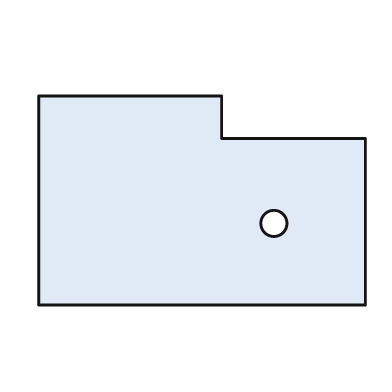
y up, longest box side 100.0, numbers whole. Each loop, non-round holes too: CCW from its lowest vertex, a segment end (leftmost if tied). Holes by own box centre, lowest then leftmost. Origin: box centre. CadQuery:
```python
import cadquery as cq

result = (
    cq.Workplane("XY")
    .moveTo(-50.0, -32.0)
    .lineTo(50.0, -32.0)
    .lineTo(50.0, 19.0)
    .lineTo(6.0, 19.0)
    .lineTo(6.0, 32.0)
    .lineTo(-50.0, 32.0)
    .close()
    .moveTo(22.0, -7.0)
    .circle(4.0)
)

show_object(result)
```